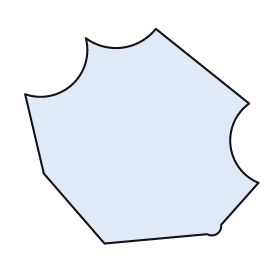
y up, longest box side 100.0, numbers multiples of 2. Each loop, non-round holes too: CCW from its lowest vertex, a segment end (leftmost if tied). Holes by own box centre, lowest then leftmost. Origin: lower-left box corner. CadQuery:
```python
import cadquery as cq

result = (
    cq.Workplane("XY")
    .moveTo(34.0, 0.0)
    .lineTo(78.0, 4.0)
    .threePointArc((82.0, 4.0), (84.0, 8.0))
    .lineTo(100.0, 26.0)
    .threePointArc((88.0, 42.0), (96.0, 60.0))
    .lineTo(56.0, 92.0)
    .threePointArc((42.0, 84.0), (26.0, 88.0))
    .threePointArc((20.0, 68.0), (0.0, 64.0))
    .lineTo(8.0, 30.0)
    .close()
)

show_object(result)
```